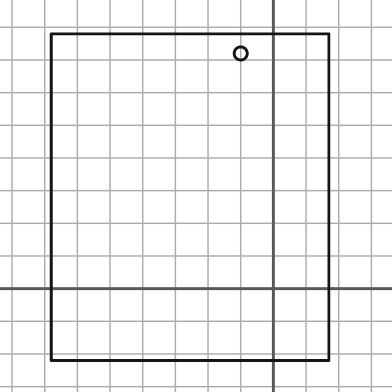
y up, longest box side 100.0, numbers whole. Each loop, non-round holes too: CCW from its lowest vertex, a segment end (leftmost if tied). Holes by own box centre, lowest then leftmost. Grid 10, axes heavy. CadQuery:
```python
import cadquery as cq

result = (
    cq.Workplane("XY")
    .moveTo(-68.0, -22.0)
    .lineTo(17.0, -22.0)
    .lineTo(17.0, 78.0)
    .lineTo(-68.0, 78.0)
    .close()
    .moveTo(-10.0, 72.0)
    .circle(2.0)
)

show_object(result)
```